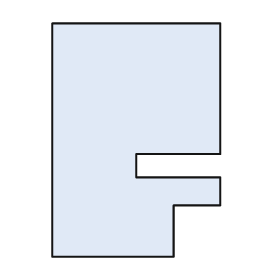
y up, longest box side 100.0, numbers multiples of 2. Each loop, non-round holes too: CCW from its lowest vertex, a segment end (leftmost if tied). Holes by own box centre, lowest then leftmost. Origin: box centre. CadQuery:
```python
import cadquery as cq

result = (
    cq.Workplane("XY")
    .moveTo(-36.0, -50.0)
    .lineTo(16.0, -50.0)
    .lineTo(16.0, -28.0)
    .lineTo(36.0, -28.0)
    .lineTo(36.0, -16.0)
    .lineTo(0.0, -16.0)
    .lineTo(0.0, -6.0)
    .lineTo(36.0, -6.0)
    .lineTo(36.0, 50.0)
    .lineTo(-36.0, 50.0)
    .close()
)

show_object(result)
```